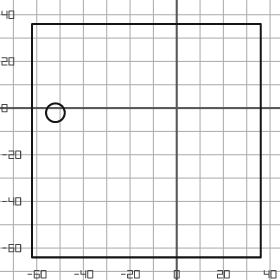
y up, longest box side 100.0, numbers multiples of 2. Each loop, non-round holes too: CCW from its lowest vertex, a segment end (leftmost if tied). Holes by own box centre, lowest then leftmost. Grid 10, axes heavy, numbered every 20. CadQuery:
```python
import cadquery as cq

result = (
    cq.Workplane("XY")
    .moveTo(-62.0, -64.0)
    .lineTo(36.0, -64.0)
    .lineTo(36.0, 36.0)
    .lineTo(-62.0, 36.0)
    .close()
    .moveTo(-52.0, -2.0)
    .circle(4.0)
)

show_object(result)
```